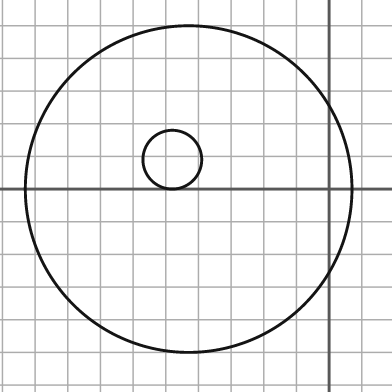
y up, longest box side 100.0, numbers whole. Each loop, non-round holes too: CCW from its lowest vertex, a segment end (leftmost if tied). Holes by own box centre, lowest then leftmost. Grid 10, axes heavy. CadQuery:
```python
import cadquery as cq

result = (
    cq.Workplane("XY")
    .moveTo(-43.0, 0.0)
    .circle(50.0)
    .moveTo(-48.0, 9.0)
    .circle(9.0)
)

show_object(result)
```